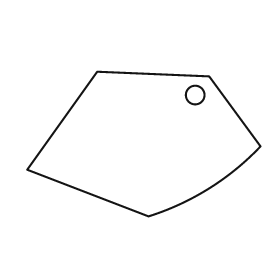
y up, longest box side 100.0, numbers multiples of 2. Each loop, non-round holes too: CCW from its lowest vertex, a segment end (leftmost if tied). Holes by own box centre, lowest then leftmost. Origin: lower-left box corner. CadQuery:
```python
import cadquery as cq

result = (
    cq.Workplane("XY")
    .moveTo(52.0, 0.0)
    .threePointArc((78.0, 12.0), (100.0, 30.0))
    .lineTo(78.0, 60.0)
    .lineTo(30.0, 62.0)
    .lineTo(0.0, 20.0)
    .close()
    .moveTo(72.0, 52.0)
    .circle(4.0)
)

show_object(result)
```